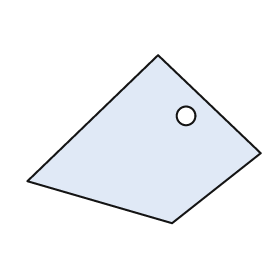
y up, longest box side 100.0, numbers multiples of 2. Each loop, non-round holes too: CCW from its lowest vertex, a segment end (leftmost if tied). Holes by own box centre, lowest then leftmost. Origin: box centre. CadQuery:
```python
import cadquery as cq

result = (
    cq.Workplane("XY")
    .moveTo(12.0, -36.0)
    .lineTo(50.0, -6.0)
    .lineTo(6.0, 36.0)
    .lineTo(-50.0, -18.0)
    .close()
    .moveTo(18.0, 10.0)
    .circle(4.0)
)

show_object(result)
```